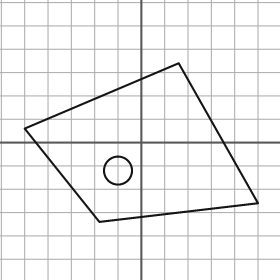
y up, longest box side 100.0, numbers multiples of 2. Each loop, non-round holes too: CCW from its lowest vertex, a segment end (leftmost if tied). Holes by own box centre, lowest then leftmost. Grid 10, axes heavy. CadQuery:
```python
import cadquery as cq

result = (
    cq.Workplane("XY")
    .moveTo(-18.0, -34.0)
    .lineTo(50.0, -26.0)
    .lineTo(16.0, 34.0)
    .lineTo(-50.0, 6.0)
    .close()
    .moveTo(-10.0, -12.0)
    .circle(6.0)
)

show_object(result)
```